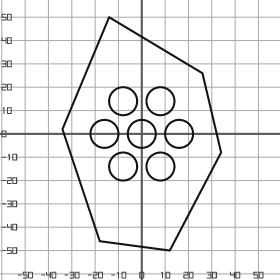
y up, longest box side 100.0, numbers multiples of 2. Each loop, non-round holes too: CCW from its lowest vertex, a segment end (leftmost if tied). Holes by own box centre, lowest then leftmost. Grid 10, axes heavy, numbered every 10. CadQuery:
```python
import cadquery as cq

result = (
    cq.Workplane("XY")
    .moveTo(12.0, -50.0)
    .lineTo(34.0, -8.0)
    .lineTo(26.0, 26.0)
    .lineTo(-14.0, 50.0)
    .lineTo(-34.0, 2.0)
    .lineTo(-18.0, -46.0)
    .close()
    .moveTo(-8.0, -14.0)
    .circle(6.0)
    .moveTo(8.0, -14.0)
    .circle(6.0)
    .moveTo(-16.0, 0.0)
    .circle(6.0)
    .moveTo(0.0, 0.0)
    .circle(6.0)
    .moveTo(16.0, 0.0)
    .circle(6.0)
    .moveTo(-8.0, 14.0)
    .circle(6.0)
    .moveTo(8.0, 14.0)
    .circle(6.0)
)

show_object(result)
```